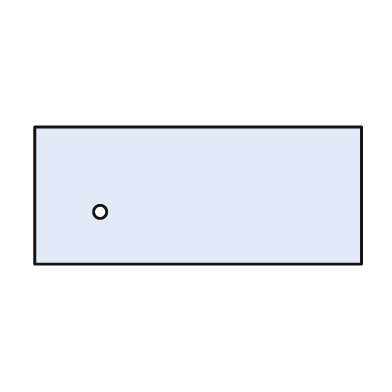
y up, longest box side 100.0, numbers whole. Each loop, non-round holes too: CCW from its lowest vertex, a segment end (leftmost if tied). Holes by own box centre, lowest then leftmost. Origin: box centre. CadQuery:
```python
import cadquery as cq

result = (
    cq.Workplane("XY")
    .moveTo(-50.0, -21.0)
    .lineTo(50.0, -21.0)
    .lineTo(50.0, 21.0)
    .lineTo(-50.0, 21.0)
    .close()
    .moveTo(-30.0, -5.0)
    .circle(2.0)
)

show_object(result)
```